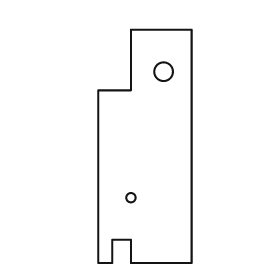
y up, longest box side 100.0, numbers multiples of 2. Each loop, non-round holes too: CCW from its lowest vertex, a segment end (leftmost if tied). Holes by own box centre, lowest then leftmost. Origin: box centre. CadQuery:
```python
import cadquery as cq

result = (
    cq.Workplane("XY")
    .moveTo(-20.0, -50.0)
    .lineTo(-14.0, -50.0)
    .lineTo(-14.0, -40.0)
    .lineTo(-6.0, -40.0)
    .lineTo(-6.0, -50.0)
    .lineTo(20.0, -50.0)
    .lineTo(20.0, 50.0)
    .lineTo(-6.0, 50.0)
    .lineTo(-6.0, 24.0)
    .lineTo(-20.0, 24.0)
    .close()
    .moveTo(-6.0, -22.0)
    .circle(2.0)
    .moveTo(8.0, 32.0)
    .circle(4.0)
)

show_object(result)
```